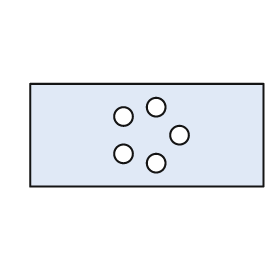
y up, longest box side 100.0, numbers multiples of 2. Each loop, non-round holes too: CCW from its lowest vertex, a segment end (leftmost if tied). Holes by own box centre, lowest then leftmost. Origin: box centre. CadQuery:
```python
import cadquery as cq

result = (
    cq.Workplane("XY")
    .moveTo(-50.0, -22.0)
    .lineTo(50.0, -22.0)
    .lineTo(50.0, 22.0)
    .lineTo(-50.0, 22.0)
    .close()
    .moveTo(4.0, -12.0)
    .circle(4.0)
    .moveTo(-10.0, -8.0)
    .circle(4.0)
    .moveTo(14.0, 0.0)
    .circle(4.0)
    .moveTo(-10.0, 8.0)
    .circle(4.0)
    .moveTo(4.0, 12.0)
    .circle(4.0)
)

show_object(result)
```